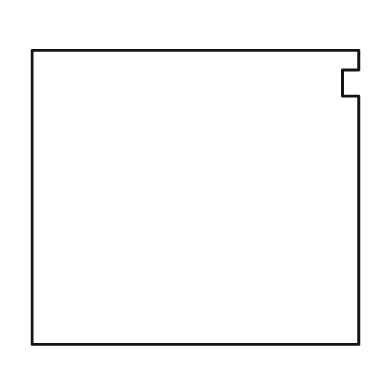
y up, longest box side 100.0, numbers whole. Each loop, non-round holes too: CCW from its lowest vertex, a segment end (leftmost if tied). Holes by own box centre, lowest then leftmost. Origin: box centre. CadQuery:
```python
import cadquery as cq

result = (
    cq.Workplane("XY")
    .moveTo(-50.0, -45.0)
    .lineTo(50.0, -45.0)
    .lineTo(50.0, 31.0)
    .lineTo(45.0, 31.0)
    .lineTo(45.0, 39.0)
    .lineTo(50.0, 39.0)
    .lineTo(50.0, 45.0)
    .lineTo(-50.0, 45.0)
    .close()
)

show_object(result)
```